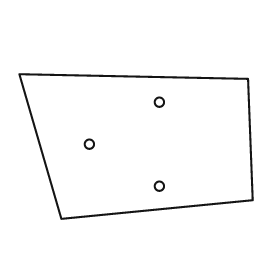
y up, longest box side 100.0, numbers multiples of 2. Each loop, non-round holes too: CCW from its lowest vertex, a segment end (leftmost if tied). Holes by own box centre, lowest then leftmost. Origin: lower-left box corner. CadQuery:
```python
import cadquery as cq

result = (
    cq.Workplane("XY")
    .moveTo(18.0, 0.0)
    .lineTo(100.0, 8.0)
    .lineTo(98.0, 60.0)
    .lineTo(0.0, 62.0)
    .close()
    .moveTo(60.0, 14.0)
    .circle(2.0)
    .moveTo(30.0, 32.0)
    .circle(2.0)
    .moveTo(60.0, 50.0)
    .circle(2.0)
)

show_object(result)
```